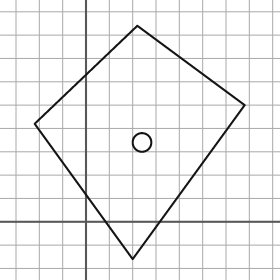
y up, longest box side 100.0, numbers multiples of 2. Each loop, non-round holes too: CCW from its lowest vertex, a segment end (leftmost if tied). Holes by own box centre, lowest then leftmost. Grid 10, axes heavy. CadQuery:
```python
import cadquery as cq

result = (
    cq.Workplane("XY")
    .moveTo(20.0, -16.0)
    .lineTo(68.0, 50.0)
    .lineTo(22.0, 84.0)
    .lineTo(-22.0, 42.0)
    .close()
    .moveTo(24.0, 34.0)
    .circle(4.0)
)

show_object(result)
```